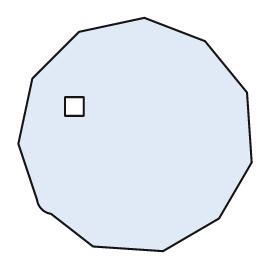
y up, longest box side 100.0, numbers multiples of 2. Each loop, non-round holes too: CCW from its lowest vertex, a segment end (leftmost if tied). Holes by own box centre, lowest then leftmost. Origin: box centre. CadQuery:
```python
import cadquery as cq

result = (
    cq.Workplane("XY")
    .moveTo(12.0, -50.0)
    .lineTo(36.0, -36.0)
    .lineTo(50.0, -12.0)
    .lineTo(48.0, 18.0)
    .lineTo(30.0, 40.0)
    .lineTo(4.0, 50.0)
    .lineTo(-24.0, 44.0)
    .lineTo(-44.0, 24.0)
    .lineTo(-50.0, -4.0)
    .lineTo(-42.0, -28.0)
    .threePointArc((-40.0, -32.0), (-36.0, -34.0))
    .lineTo(-18.0, -48.0)
    .close()
    .moveTo(-30.0, 8.0)
    .lineTo(-22.0, 8.0)
    .lineTo(-22.0, 16.0)
    .lineTo(-30.0, 16.0)
    .close()
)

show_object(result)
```